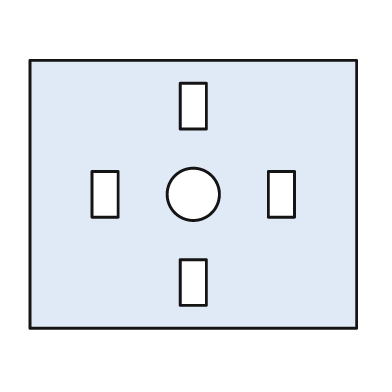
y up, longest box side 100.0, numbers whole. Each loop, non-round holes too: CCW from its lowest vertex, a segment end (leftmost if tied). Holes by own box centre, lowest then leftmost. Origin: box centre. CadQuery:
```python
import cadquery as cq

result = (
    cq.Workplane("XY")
    .moveTo(-50.0, -41.0)
    .lineTo(50.0, -41.0)
    .lineTo(50.0, 41.0)
    .lineTo(-50.0, 41.0)
    .close()
    .moveTo(-4.0, -34.0)
    .lineTo(4.0, -34.0)
    .lineTo(4.0, -20.0)
    .lineTo(-4.0, -20.0)
    .close()
    .moveTo(-31.0, -7.0)
    .lineTo(-23.0, -7.0)
    .lineTo(-23.0, 7.0)
    .lineTo(-31.0, 7.0)
    .close()
    .moveTo(0.0, 0.0)
    .circle(8.0)
    .moveTo(23.0, -7.0)
    .lineTo(31.0, -7.0)
    .lineTo(31.0, 7.0)
    .lineTo(23.0, 7.0)
    .close()
    .moveTo(-4.0, 20.0)
    .lineTo(4.0, 20.0)
    .lineTo(4.0, 34.0)
    .lineTo(-4.0, 34.0)
    .close()
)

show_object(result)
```